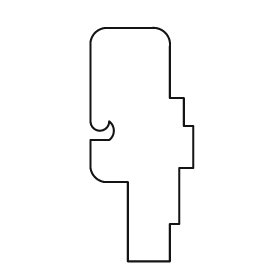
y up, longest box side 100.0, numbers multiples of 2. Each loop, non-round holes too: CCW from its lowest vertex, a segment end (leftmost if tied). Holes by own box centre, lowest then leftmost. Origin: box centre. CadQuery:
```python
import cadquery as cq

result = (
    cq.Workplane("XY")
    .moveTo(-6.0, -50.0)
    .lineTo(12.0, -50.0)
    .lineTo(12.0, -34.0)
    .lineTo(16.0, -34.0)
    .lineTo(16.0, -10.0)
    .lineTo(22.0, -10.0)
    .lineTo(22.0, 8.0)
    .lineTo(18.0, 8.0)
    .lineTo(18.0, 20.0)
    .lineTo(12.0, 20.0)
    .lineTo(12.0, 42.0)
    .threePointArc((10.0, 48.0), (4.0, 50.0))
    .lineTo(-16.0, 50.0)
    .threePointArc((-20.0, 48.0), (-22.0, 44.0))
    .lineTo(-22.0, 10.0)
    .threePointArc((-18.0, 6.0), (-14.0, 10.0))
    .threePointArc((-12.0, 6.0), (-14.0, 2.0))
    .lineTo(-22.0, 2.0)
    .lineTo(-22.0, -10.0)
    .threePointArc((-20.0, -14.0), (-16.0, -16.0))
    .lineTo(-6.0, -16.0)
    .close()
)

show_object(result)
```